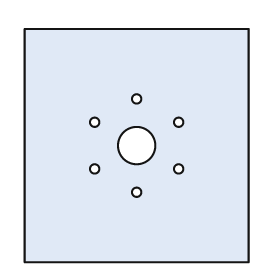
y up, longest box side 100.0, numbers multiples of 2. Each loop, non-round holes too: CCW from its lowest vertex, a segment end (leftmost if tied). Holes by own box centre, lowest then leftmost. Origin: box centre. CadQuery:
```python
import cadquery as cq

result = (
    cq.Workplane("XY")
    .moveTo(-48.0, -50.0)
    .lineTo(48.0, -50.0)
    .lineTo(48.0, 50.0)
    .lineTo(-48.0, 50.0)
    .close()
    .moveTo(0.0, -20.0)
    .circle(2.0)
    .moveTo(-18.0, -10.0)
    .circle(2.0)
    .moveTo(18.0, -10.0)
    .circle(2.0)
    .moveTo(0.0, 0.0)
    .circle(8.0)
    .moveTo(-18.0, 10.0)
    .circle(2.0)
    .moveTo(18.0, 10.0)
    .circle(2.0)
    .moveTo(0.0, 20.0)
    .circle(2.0)
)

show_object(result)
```